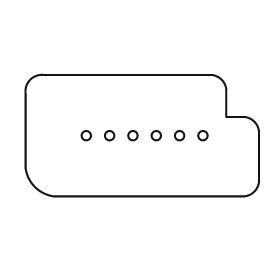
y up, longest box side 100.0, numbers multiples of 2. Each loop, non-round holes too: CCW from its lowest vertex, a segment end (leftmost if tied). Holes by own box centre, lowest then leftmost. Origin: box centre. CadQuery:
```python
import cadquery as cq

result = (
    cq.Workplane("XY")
    .moveTo(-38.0, -26.0)
    .lineTo(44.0, -26.0)
    .threePointArc((48.0, -24.0), (50.0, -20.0))
    .lineTo(50.0, 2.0)
    .threePointArc((48.0, 6.0), (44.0, 8.0))
    .lineTo(36.0, 8.0)
    .lineTo(36.0, 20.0)
    .threePointArc((34.0, 24.0), (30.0, 26.0))
    .lineTo(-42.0, 26.0)
    .threePointArc((-48.0, 24.0), (-50.0, 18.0))
    .lineTo(-50.0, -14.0)
    .threePointArc((-46.0, -22.0), (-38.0, -26.0))
    .close()
    .moveTo(-24.0, 0.0)
    .circle(2.0)
    .moveTo(-14.0, 0.0)
    .circle(2.0)
    .moveTo(-4.0, 0.0)
    .circle(2.0)
    .moveTo(6.0, 0.0)
    .circle(2.0)
    .moveTo(16.0, 0.0)
    .circle(2.0)
    .moveTo(26.0, 0.0)
    .circle(2.0)
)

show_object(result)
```